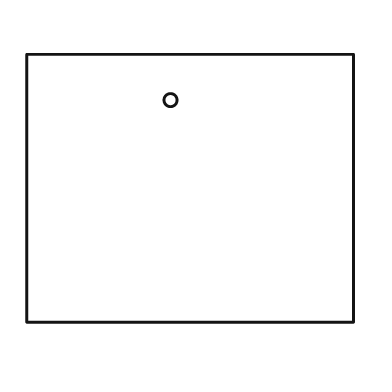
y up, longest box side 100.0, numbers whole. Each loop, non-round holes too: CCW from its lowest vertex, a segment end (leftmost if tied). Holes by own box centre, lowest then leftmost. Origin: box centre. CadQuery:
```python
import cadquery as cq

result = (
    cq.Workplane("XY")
    .moveTo(-50.0, -41.0)
    .lineTo(50.0, -41.0)
    .lineTo(50.0, 41.0)
    .lineTo(-50.0, 41.0)
    .close()
    .moveTo(-6.0, 27.0)
    .circle(2.0)
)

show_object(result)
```